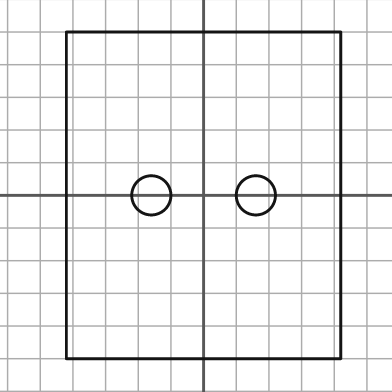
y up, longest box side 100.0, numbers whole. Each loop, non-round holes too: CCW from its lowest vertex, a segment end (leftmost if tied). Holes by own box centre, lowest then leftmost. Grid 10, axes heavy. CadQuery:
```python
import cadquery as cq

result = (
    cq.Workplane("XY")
    .moveTo(-42.0, -50.0)
    .lineTo(42.0, -50.0)
    .lineTo(42.0, 50.0)
    .lineTo(-42.0, 50.0)
    .close()
    .moveTo(-16.0, 0.0)
    .circle(6.0)
    .moveTo(16.0, 0.0)
    .circle(6.0)
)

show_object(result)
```